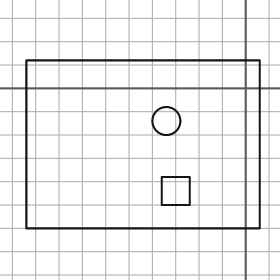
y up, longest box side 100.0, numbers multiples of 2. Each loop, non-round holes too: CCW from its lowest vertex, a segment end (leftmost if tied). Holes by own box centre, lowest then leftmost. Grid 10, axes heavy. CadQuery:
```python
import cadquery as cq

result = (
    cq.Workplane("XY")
    .moveTo(-94.0, -60.0)
    .lineTo(6.0, -60.0)
    .lineTo(6.0, 12.0)
    .lineTo(-94.0, 12.0)
    .close()
    .moveTo(-36.0, -50.0)
    .lineTo(-24.0, -50.0)
    .lineTo(-24.0, -38.0)
    .lineTo(-36.0, -38.0)
    .close()
    .moveTo(-34.0, -14.0)
    .circle(6.0)
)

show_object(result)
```